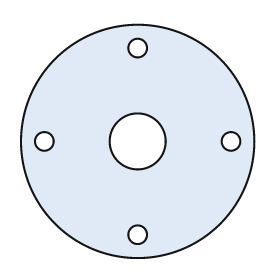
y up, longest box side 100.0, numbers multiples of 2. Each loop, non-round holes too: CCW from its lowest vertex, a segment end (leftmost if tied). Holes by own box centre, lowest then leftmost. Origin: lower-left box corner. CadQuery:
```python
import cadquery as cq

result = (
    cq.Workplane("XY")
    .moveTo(50.0, 50.0)
    .circle(50.0)
    .moveTo(50.0, 10.0)
    .circle(4.0)
    .moveTo(10.0, 50.0)
    .circle(4.0)
    .moveTo(50.0, 50.0)
    .circle(12.0)
    .moveTo(90.0, 50.0)
    .circle(4.0)
    .moveTo(50.0, 90.0)
    .circle(4.0)
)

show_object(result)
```